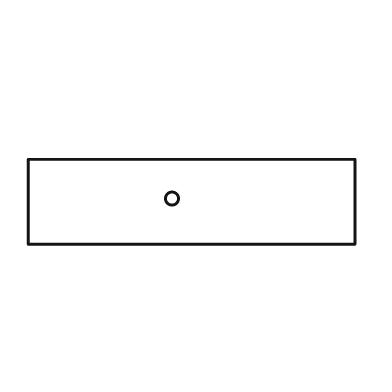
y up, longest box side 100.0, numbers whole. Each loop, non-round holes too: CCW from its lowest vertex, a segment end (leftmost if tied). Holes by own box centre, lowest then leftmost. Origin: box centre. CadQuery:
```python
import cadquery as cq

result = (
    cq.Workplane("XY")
    .moveTo(-50.0, -13.0)
    .lineTo(50.0, -13.0)
    .lineTo(50.0, 13.0)
    .lineTo(-50.0, 13.0)
    .close()
    .moveTo(-6.0, 1.0)
    .circle(2.0)
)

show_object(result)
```